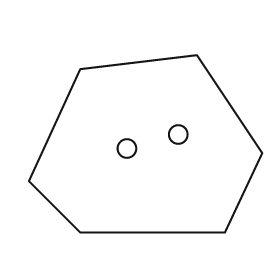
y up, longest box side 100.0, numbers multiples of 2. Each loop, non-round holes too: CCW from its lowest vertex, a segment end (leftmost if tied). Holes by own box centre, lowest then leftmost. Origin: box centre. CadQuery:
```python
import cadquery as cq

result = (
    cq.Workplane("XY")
    .moveTo(-28.0, -38.0)
    .lineTo(34.0, -38.0)
    .lineTo(50.0, -4.0)
    .lineTo(22.0, 38.0)
    .lineTo(-28.0, 32.0)
    .lineTo(-50.0, -16.0)
    .close()
    .moveTo(-8.0, -2.0)
    .circle(4.0)
    .moveTo(14.0, 4.0)
    .circle(4.0)
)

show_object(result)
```